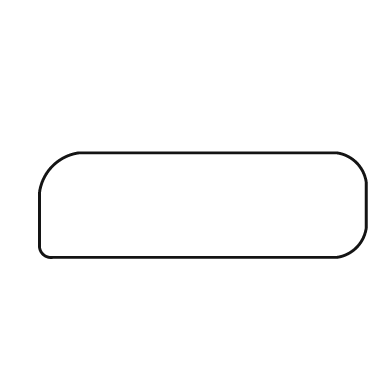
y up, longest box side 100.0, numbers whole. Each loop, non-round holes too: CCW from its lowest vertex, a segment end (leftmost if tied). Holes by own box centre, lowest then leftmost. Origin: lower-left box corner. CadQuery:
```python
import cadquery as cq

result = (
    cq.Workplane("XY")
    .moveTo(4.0, 0.0)
    .lineTo(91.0, 0.0)
    .threePointArc((97.0, 3.0), (100.0, 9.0))
    .lineTo(100.0, 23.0)
    .threePointArc((97.0, 29.0), (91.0, 32.0))
    .lineTo(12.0, 32.0)
    .threePointArc((4.0, 28.0), (0.0, 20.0))
    .lineTo(0.0, 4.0)
    .threePointArc((1.0, 1.0), (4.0, 0.0))
    .close()
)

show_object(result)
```